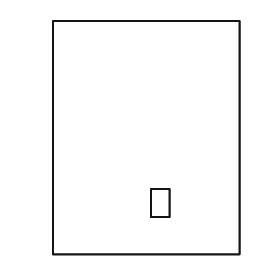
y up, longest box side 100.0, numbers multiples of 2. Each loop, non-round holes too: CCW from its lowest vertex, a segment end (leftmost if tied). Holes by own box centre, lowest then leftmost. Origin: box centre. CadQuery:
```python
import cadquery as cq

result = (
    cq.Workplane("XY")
    .moveTo(-40.0, -50.0)
    .lineTo(40.0, -50.0)
    .lineTo(40.0, 50.0)
    .lineTo(-40.0, 50.0)
    .close()
    .moveTo(2.0, -34.0)
    .lineTo(10.0, -34.0)
    .lineTo(10.0, -22.0)
    .lineTo(2.0, -22.0)
    .close()
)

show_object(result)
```